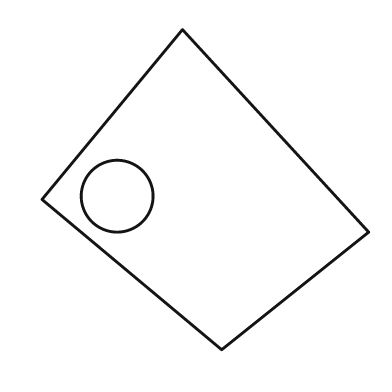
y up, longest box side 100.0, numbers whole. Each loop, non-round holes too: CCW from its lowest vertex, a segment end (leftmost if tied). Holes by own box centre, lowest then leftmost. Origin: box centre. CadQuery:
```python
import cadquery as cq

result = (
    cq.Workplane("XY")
    .moveTo(5.0, -49.0)
    .lineTo(50.0, -13.0)
    .lineTo(-7.0, 49.0)
    .lineTo(-50.0, -3.0)
    .close()
    .moveTo(-27.0, -2.0)
    .circle(11.0)
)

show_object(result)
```